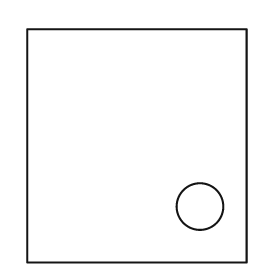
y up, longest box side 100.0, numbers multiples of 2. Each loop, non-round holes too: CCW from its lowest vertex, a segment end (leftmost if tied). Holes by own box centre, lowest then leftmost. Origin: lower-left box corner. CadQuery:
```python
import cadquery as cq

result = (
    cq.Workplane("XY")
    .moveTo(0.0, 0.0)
    .lineTo(94.0, 0.0)
    .lineTo(94.0, 100.0)
    .lineTo(0.0, 100.0)
    .close()
    .moveTo(74.0, 24.0)
    .circle(10.0)
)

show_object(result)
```